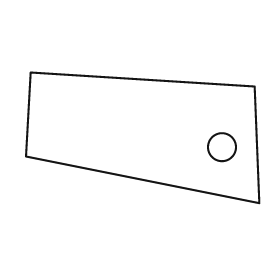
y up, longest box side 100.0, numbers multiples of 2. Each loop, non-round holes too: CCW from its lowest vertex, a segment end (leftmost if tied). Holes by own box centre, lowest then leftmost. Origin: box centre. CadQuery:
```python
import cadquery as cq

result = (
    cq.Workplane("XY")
    .moveTo(50.0, -28.0)
    .lineTo(48.0, 22.0)
    .lineTo(-48.0, 28.0)
    .lineTo(-50.0, -8.0)
    .close()
    .moveTo(34.0, -4.0)
    .circle(6.0)
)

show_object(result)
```